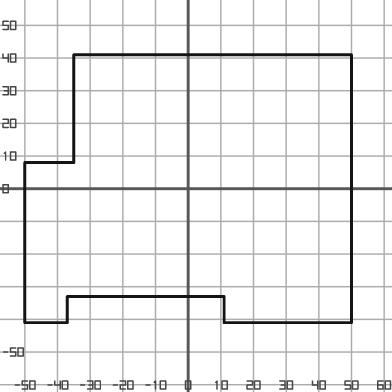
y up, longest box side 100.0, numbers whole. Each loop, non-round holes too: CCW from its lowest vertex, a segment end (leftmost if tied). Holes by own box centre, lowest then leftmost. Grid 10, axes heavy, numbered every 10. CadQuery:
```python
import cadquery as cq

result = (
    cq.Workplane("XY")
    .moveTo(-50.0, -41.0)
    .lineTo(-37.0, -41.0)
    .lineTo(-37.0, -33.0)
    .lineTo(11.0, -33.0)
    .lineTo(11.0, -41.0)
    .lineTo(50.0, -41.0)
    .lineTo(50.0, 41.0)
    .lineTo(-35.0, 41.0)
    .lineTo(-35.0, 8.0)
    .lineTo(-50.0, 8.0)
    .close()
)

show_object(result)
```